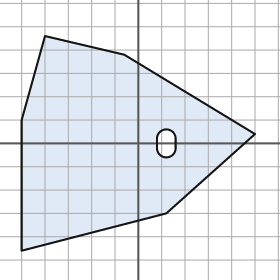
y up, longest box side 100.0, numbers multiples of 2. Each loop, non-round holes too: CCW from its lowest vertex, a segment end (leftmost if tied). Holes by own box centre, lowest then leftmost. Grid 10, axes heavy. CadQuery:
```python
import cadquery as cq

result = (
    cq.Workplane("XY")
    .moveTo(-50.0, -46.0)
    .lineTo(12.0, -30.0)
    .lineTo(50.0, 4.0)
    .lineTo(-6.0, 38.0)
    .lineTo(-40.0, 46.0)
    .lineTo(-50.0, 10.0)
    .close()
    .moveTo(8.0, -2.0)
    .threePointArc((12.0, -6.0), (16.0, -2.0))
    .lineTo(16.0, 2.0)
    .threePointArc((12.0, 6.0), (8.0, 2.0))
    .close()
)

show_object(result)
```